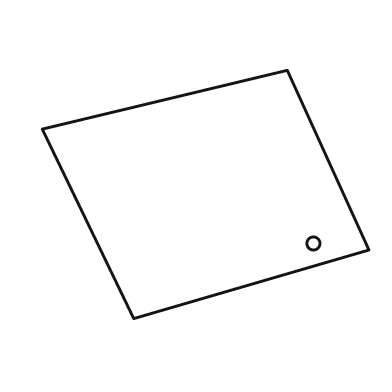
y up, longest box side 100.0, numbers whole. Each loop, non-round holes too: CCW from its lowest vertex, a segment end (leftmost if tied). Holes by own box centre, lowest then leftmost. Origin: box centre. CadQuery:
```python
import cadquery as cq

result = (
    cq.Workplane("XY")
    .moveTo(-22.0, -38.0)
    .lineTo(50.0, -17.0)
    .lineTo(25.0, 38.0)
    .lineTo(-50.0, 20.0)
    .close()
    .moveTo(33.0, -15.0)
    .circle(2.0)
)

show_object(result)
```